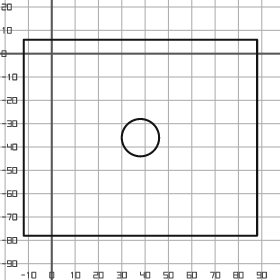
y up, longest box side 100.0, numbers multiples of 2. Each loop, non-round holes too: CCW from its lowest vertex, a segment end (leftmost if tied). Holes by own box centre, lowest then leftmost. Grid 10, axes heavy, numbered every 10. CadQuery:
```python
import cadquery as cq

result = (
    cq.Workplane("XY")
    .moveTo(-12.0, -78.0)
    .lineTo(88.0, -78.0)
    .lineTo(88.0, 6.0)
    .lineTo(-12.0, 6.0)
    .close()
    .moveTo(38.0, -36.0)
    .circle(8.0)
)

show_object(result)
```